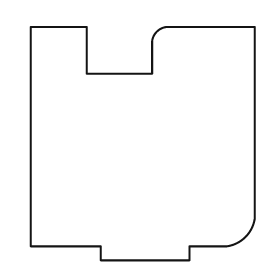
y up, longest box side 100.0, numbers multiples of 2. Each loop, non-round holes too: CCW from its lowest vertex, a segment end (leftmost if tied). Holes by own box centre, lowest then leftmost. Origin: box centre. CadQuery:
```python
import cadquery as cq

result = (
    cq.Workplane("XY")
    .moveTo(-18.0, -50.0)
    .lineTo(20.0, -50.0)
    .lineTo(20.0, -44.0)
    .lineTo(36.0, -44.0)
    .threePointArc((44.0, -40.0), (48.0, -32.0))
    .lineTo(48.0, 50.0)
    .lineTo(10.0, 50.0)
    .threePointArc((6.0, 48.0), (4.0, 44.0))
    .lineTo(4.0, 30.0)
    .lineTo(-24.0, 30.0)
    .lineTo(-24.0, 50.0)
    .lineTo(-48.0, 50.0)
    .lineTo(-48.0, -44.0)
    .lineTo(-18.0, -44.0)
    .close()
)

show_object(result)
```